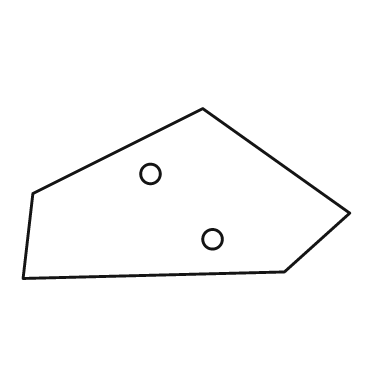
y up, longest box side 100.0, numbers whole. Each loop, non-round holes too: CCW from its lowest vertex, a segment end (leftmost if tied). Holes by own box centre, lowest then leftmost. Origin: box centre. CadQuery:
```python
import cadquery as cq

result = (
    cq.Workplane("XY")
    .moveTo(-50.0, -26.0)
    .lineTo(30.0, -24.0)
    .lineTo(50.0, -6.0)
    .lineTo(5.0, 26.0)
    .lineTo(-47.0, 0.0)
    .close()
    .moveTo(8.0, -14.0)
    .circle(3.0)
    .moveTo(-11.0, 6.0)
    .circle(3.0)
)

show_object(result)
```